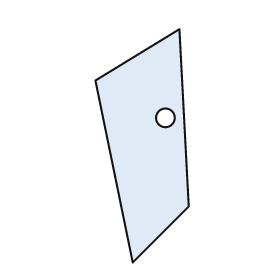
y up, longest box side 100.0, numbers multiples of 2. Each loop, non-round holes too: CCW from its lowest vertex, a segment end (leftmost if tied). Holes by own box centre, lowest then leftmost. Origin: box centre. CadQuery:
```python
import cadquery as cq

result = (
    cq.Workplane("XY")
    .moveTo(-4.0, -50.0)
    .lineTo(20.0, -26.0)
    .lineTo(16.0, 50.0)
    .lineTo(-20.0, 28.0)
    .close()
    .moveTo(10.0, 12.0)
    .circle(4.0)
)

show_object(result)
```